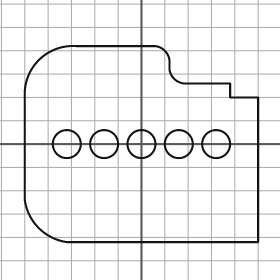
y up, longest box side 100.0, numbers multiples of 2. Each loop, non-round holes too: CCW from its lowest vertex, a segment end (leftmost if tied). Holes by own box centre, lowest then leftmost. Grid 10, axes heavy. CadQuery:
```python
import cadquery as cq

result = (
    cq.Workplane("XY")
    .moveTo(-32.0, -42.0)
    .lineTo(50.0, -42.0)
    .lineTo(50.0, 20.0)
    .lineTo(38.0, 20.0)
    .lineTo(38.0, 26.0)
    .lineTo(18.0, 26.0)
    .threePointArc((14.0, 28.0), (12.0, 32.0))
    .lineTo(12.0, 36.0)
    .threePointArc((10.0, 40.0), (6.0, 42.0))
    .lineTo(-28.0, 42.0)
    .threePointArc((-44.0, 36.0), (-50.0, 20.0))
    .lineTo(-50.0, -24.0)
    .threePointArc((-44.0, -36.0), (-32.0, -42.0))
    .close()
    .moveTo(-32.0, 0.0)
    .circle(6.0)
    .moveTo(-16.0, 0.0)
    .circle(6.0)
    .moveTo(0.0, 0.0)
    .circle(6.0)
    .moveTo(16.0, 0.0)
    .circle(6.0)
    .moveTo(32.0, 0.0)
    .circle(6.0)
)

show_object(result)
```